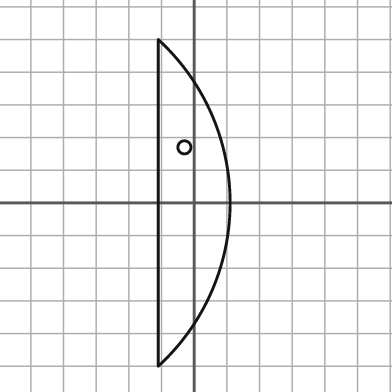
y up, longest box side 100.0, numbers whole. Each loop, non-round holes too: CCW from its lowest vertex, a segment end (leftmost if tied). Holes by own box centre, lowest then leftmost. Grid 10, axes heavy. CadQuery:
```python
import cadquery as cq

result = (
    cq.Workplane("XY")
    .moveTo(-11.0, -50.0)
    .threePointArc((11.0, 0.0), (-11.0, 50.0))
    .close()
    .moveTo(-3.0, 17.0)
    .circle(2.0)
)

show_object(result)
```